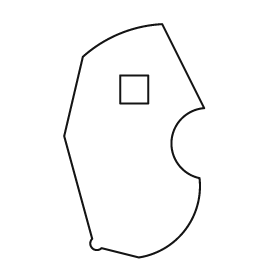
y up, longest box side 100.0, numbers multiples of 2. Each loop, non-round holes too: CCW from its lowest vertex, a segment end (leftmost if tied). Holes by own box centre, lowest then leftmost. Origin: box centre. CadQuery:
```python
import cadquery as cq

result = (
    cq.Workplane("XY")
    .moveTo(2.0, -50.0)
    .threePointArc((22.0, -38.0), (28.0, -16.0))
    .threePointArc((16.0, 0.0), (30.0, 14.0))
    .lineTo(12.0, 50.0)
    .threePointArc((-6.0, 46.0), (-22.0, 36.0))
    .lineTo(-30.0, 2.0)
    .lineTo(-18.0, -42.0)
    .threePointArc((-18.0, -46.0), (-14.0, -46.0))
    .close()
    .moveTo(-6.0, 16.0)
    .lineTo(6.0, 16.0)
    .lineTo(6.0, 28.0)
    .lineTo(-6.0, 28.0)
    .close()
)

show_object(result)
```